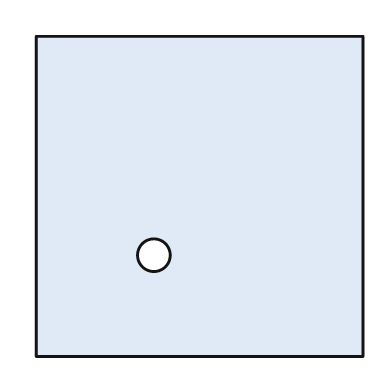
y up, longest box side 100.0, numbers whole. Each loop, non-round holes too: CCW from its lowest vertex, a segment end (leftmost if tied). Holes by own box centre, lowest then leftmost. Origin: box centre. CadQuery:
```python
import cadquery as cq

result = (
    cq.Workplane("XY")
    .moveTo(-50.0, -49.0)
    .lineTo(50.0, -49.0)
    .lineTo(50.0, 49.0)
    .lineTo(-50.0, 49.0)
    .close()
    .moveTo(-14.0, -18.0)
    .circle(5.0)
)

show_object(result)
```